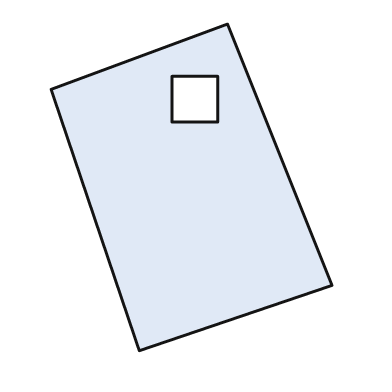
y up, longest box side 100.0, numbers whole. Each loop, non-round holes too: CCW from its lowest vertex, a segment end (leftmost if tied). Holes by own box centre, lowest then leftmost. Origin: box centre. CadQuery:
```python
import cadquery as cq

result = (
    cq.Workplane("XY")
    .moveTo(-16.0, -50.0)
    .lineTo(43.0, -30.0)
    .lineTo(11.0, 50.0)
    .lineTo(-43.0, 30.0)
    .close()
    .moveTo(-6.0, 20.0)
    .lineTo(8.0, 20.0)
    .lineTo(8.0, 34.0)
    .lineTo(-6.0, 34.0)
    .close()
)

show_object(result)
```